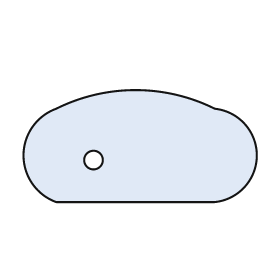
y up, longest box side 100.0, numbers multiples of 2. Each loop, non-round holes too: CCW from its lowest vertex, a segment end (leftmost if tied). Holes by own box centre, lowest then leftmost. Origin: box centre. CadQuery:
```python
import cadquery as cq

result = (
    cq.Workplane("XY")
    .moveTo(-36.0, -24.0)
    .lineTo(32.0, -24.0)
    .threePointArc((50.0, -4.0), (32.0, 16.0))
    .threePointArc((-2.0, 24.0), (-36.0, 16.0))
    .threePointArc((-50.0, -4.0), (-36.0, -24.0))
    .close()
    .moveTo(-20.0, -6.0)
    .circle(4.0)
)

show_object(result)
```